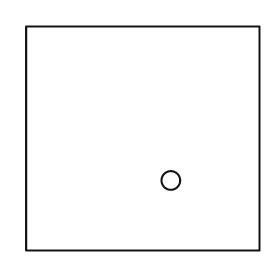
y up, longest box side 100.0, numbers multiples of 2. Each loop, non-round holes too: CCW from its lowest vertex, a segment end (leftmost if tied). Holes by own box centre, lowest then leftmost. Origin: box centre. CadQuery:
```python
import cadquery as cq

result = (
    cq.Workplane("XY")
    .moveTo(-50.0, -48.0)
    .lineTo(50.0, -48.0)
    .lineTo(50.0, 48.0)
    .lineTo(-50.0, 48.0)
    .close()
    .moveTo(12.0, -18.0)
    .circle(4.0)
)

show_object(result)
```